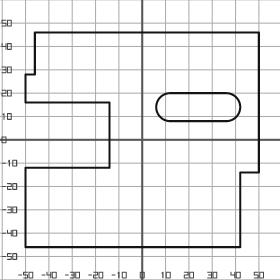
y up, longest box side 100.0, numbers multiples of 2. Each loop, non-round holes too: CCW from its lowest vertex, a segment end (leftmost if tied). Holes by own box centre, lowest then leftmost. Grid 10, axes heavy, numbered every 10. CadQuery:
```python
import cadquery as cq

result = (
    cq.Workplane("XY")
    .moveTo(-50.0, -46.0)
    .lineTo(42.0, -46.0)
    .lineTo(42.0, -14.0)
    .lineTo(50.0, -14.0)
    .lineTo(50.0, 46.0)
    .lineTo(-46.0, 46.0)
    .lineTo(-46.0, 28.0)
    .lineTo(-50.0, 28.0)
    .lineTo(-50.0, 16.0)
    .lineTo(-14.0, 16.0)
    .lineTo(-14.0, -12.0)
    .lineTo(-50.0, -12.0)
    .close()
    .moveTo(12.0, 8.0)
    .lineTo(36.0, 8.0)
    .threePointArc((42.0, 14.0), (36.0, 20.0))
    .lineTo(12.0, 20.0)
    .threePointArc((6.0, 14.0), (12.0, 8.0))
    .close()
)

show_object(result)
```